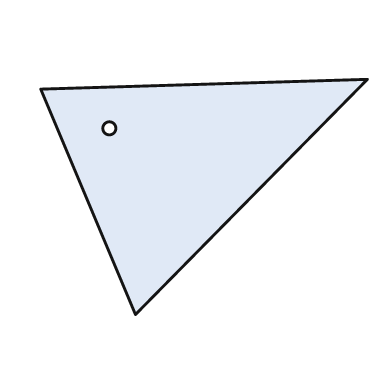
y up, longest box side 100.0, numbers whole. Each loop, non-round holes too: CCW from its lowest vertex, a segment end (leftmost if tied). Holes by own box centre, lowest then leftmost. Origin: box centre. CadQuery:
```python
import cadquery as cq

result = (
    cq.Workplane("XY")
    .moveTo(-21.0, -36.0)
    .lineTo(50.0, 36.0)
    .lineTo(-50.0, 33.0)
    .close()
    .moveTo(-29.0, 21.0)
    .circle(2.0)
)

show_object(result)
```